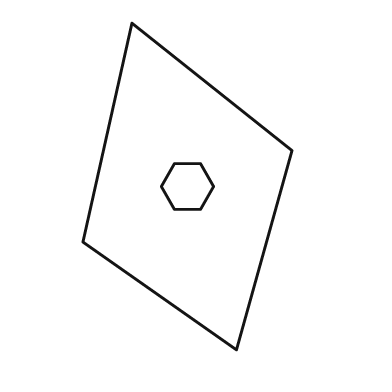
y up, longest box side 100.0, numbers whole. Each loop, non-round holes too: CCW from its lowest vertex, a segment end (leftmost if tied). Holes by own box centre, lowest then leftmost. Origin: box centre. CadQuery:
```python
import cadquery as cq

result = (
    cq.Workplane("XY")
    .moveTo(15.0, -50.0)
    .lineTo(32.0, 11.0)
    .lineTo(-17.0, 50.0)
    .lineTo(-32.0, -17.0)
    .close()
    .moveTo(-4.0, -7.0)
    .lineTo(4.0, -7.0)
    .lineTo(8.0, 0.0)
    .lineTo(4.0, 7.0)
    .lineTo(-4.0, 7.0)
    .lineTo(-8.0, 0.0)
    .close()
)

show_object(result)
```